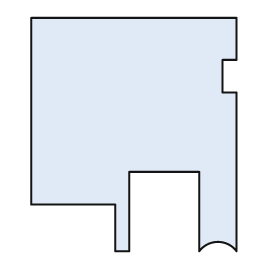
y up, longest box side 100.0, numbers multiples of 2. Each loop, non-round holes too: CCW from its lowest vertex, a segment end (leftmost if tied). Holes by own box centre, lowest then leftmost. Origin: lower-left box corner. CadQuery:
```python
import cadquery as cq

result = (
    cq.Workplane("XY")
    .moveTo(36.0, 0.0)
    .lineTo(42.0, 0.0)
    .lineTo(42.0, 34.0)
    .lineTo(72.0, 34.0)
    .lineTo(72.0, 0.0)
    .threePointArc((80.0, 4.0), (88.0, 0.0))
    .lineTo(88.0, 68.0)
    .lineTo(82.0, 68.0)
    .lineTo(82.0, 82.0)
    .lineTo(88.0, 82.0)
    .lineTo(88.0, 100.0)
    .lineTo(0.0, 100.0)
    .lineTo(0.0, 20.0)
    .lineTo(36.0, 20.0)
    .close()
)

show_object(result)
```